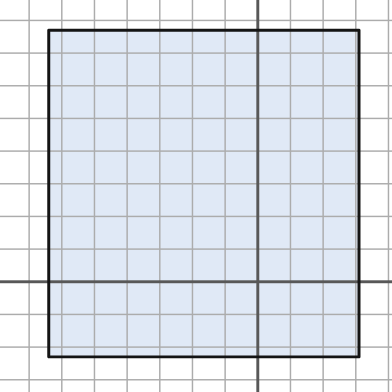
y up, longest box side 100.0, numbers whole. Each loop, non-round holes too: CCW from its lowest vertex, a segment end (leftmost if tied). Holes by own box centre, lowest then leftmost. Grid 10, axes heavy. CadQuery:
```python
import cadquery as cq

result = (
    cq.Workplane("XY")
    .moveTo(-64.0, -23.0)
    .lineTo(31.0, -23.0)
    .lineTo(31.0, 77.0)
    .lineTo(-64.0, 77.0)
    .close()
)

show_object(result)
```